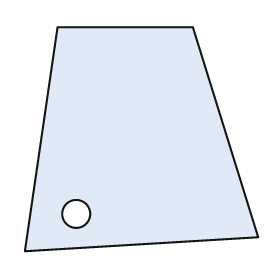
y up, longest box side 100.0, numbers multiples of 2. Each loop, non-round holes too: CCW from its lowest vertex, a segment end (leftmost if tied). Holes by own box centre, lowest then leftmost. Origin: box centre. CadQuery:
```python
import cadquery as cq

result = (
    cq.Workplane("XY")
    .moveTo(-50.0, -48.0)
    .lineTo(50.0, -42.0)
    .lineTo(22.0, 48.0)
    .lineTo(-36.0, 48.0)
    .close()
    .moveTo(-28.0, -32.0)
    .circle(6.0)
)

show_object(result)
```